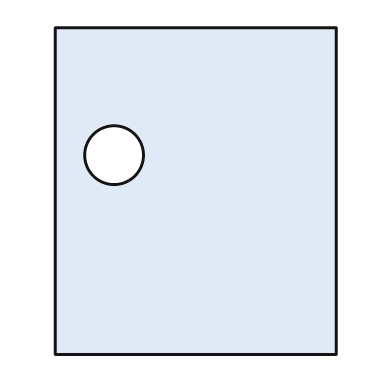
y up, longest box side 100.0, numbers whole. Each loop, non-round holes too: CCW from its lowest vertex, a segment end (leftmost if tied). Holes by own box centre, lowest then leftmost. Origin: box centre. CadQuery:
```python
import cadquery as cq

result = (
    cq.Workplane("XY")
    .moveTo(-43.0, -50.0)
    .lineTo(43.0, -50.0)
    .lineTo(43.0, 50.0)
    .lineTo(-43.0, 50.0)
    .close()
    .moveTo(-25.0, 11.0)
    .circle(9.0)
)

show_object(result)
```